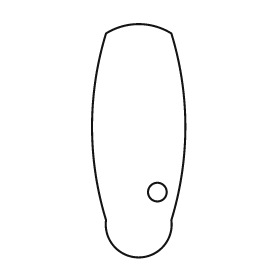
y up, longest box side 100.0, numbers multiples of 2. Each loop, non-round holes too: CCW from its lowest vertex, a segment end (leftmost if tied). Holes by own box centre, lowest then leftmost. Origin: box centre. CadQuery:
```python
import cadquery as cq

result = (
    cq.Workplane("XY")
    .moveTo(-14.0, -34.0)
    .threePointArc((0.0, -50.0), (14.0, -34.0))
    .threePointArc((20.0, 6.0), (14.0, 46.0))
    .threePointArc((0.0, 50.0), (-14.0, 46.0))
    .threePointArc((-20.0, 6.0), (-14.0, -34.0))
    .close()
    .moveTo(8.0, -22.0)
    .circle(4.0)
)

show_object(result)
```